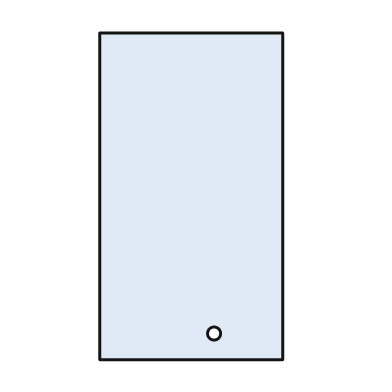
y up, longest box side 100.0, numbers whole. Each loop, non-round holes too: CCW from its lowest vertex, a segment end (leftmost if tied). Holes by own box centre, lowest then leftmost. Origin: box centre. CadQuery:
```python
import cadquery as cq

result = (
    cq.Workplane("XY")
    .moveTo(-28.0, -50.0)
    .lineTo(28.0, -50.0)
    .lineTo(28.0, 50.0)
    .lineTo(-28.0, 50.0)
    .close()
    .moveTo(7.0, -42.0)
    .circle(2.0)
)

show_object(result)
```